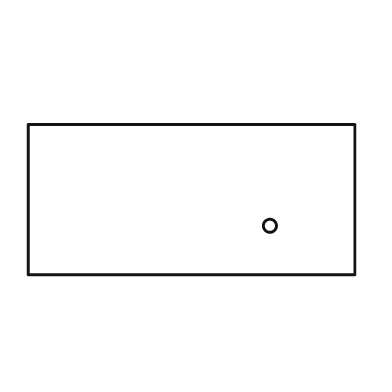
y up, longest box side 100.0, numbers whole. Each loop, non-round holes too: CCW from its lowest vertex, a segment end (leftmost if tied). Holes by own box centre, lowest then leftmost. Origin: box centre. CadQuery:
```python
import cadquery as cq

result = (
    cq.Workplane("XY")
    .moveTo(-50.0, -23.0)
    .lineTo(50.0, -23.0)
    .lineTo(50.0, 23.0)
    .lineTo(-50.0, 23.0)
    .close()
    .moveTo(24.0, -8.0)
    .circle(2.0)
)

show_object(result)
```